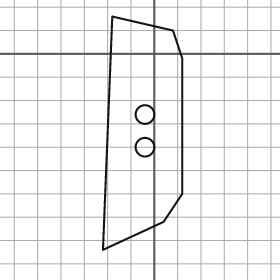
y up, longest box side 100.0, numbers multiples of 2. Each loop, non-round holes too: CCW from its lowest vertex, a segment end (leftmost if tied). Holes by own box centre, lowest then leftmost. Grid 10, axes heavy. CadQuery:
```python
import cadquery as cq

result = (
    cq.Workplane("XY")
    .moveTo(-22.0, -84.0)
    .lineTo(4.0, -72.0)
    .lineTo(12.0, -60.0)
    .lineTo(12.0, -2.0)
    .lineTo(8.0, 10.0)
    .lineTo(-18.0, 16.0)
    .close()
    .moveTo(-4.0, -40.0)
    .circle(4.0)
    .moveTo(-4.0, -26.0)
    .circle(4.0)
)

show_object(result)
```